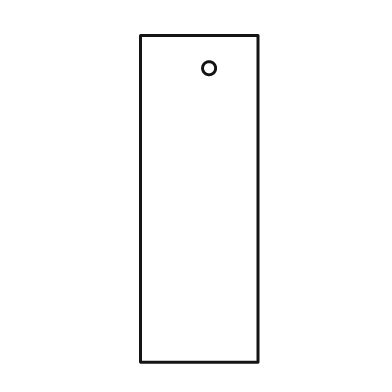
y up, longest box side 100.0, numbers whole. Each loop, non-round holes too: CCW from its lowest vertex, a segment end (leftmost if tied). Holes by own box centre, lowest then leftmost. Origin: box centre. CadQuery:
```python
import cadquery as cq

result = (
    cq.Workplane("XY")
    .moveTo(-18.0, -50.0)
    .lineTo(18.0, -50.0)
    .lineTo(18.0, 50.0)
    .lineTo(-18.0, 50.0)
    .close()
    .moveTo(3.0, 40.0)
    .circle(2.0)
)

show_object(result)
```